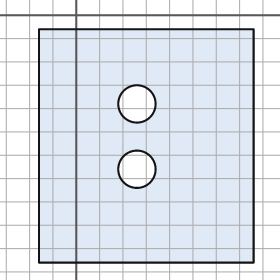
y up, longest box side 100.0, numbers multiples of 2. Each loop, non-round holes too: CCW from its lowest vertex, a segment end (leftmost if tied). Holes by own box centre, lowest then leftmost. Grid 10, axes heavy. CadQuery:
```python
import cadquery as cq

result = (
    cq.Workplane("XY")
    .moveTo(-16.0, -106.0)
    .lineTo(76.0, -106.0)
    .lineTo(76.0, -6.0)
    .lineTo(-16.0, -6.0)
    .close()
    .moveTo(26.0, -66.0)
    .circle(8.0)
    .moveTo(26.0, -38.0)
    .circle(8.0)
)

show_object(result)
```